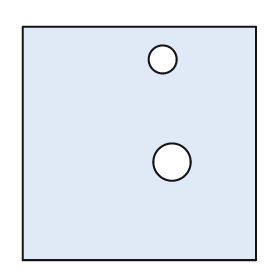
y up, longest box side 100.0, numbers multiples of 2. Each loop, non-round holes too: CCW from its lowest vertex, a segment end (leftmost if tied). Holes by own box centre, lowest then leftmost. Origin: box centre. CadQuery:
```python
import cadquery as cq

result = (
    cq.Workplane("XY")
    .moveTo(-50.0, -50.0)
    .lineTo(50.0, -50.0)
    .lineTo(50.0, 50.0)
    .lineTo(-50.0, 50.0)
    .close()
    .moveTo(14.0, -8.0)
    .circle(8.0)
    .moveTo(10.0, 36.0)
    .circle(6.0)
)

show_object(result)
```